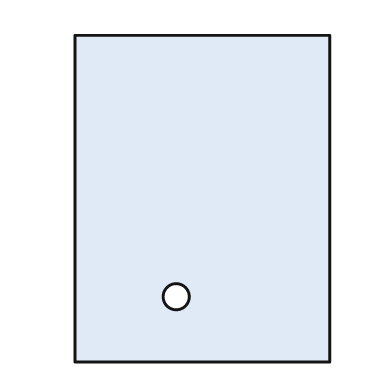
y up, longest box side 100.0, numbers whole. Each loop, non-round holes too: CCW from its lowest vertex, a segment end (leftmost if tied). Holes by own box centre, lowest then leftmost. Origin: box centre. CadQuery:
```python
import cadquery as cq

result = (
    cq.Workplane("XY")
    .moveTo(-39.0, -50.0)
    .lineTo(39.0, -50.0)
    .lineTo(39.0, 50.0)
    .lineTo(-39.0, 50.0)
    .close()
    .moveTo(-8.0, -30.0)
    .circle(4.0)
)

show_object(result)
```